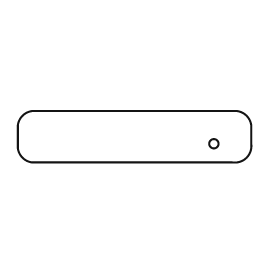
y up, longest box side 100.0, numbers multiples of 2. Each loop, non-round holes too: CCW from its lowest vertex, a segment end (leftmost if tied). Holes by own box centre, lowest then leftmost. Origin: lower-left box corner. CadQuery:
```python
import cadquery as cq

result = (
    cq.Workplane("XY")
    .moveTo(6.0, 0.0)
    .lineTo(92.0, 0.0)
    .threePointArc((98.0, 2.0), (100.0, 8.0))
    .lineTo(100.0, 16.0)
    .threePointArc((98.0, 20.0), (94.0, 22.0))
    .lineTo(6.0, 22.0)
    .threePointArc((2.0, 20.0), (0.0, 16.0))
    .lineTo(0.0, 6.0)
    .threePointArc((2.0, 2.0), (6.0, 0.0))
    .close()
    .moveTo(84.0, 8.0)
    .circle(2.0)
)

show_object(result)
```